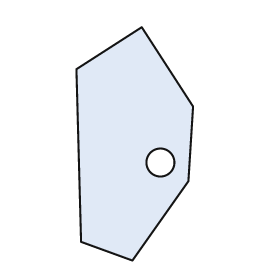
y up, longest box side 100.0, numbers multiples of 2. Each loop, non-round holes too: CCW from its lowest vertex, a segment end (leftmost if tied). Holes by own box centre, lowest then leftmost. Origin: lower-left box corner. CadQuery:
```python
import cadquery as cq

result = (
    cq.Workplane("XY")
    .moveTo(24.0, 0.0)
    .lineTo(48.0, 34.0)
    .lineTo(50.0, 66.0)
    .lineTo(28.0, 100.0)
    .lineTo(0.0, 82.0)
    .lineTo(2.0, 8.0)
    .close()
    .moveTo(36.0, 42.0)
    .circle(6.0)
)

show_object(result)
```